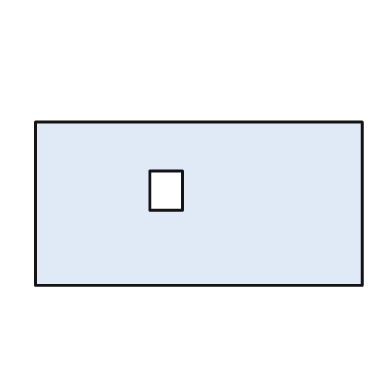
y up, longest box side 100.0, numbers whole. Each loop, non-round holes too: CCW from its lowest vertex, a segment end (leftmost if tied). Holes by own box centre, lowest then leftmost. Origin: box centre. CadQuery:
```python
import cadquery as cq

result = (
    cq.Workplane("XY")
    .moveTo(-50.0, -25.0)
    .lineTo(50.0, -25.0)
    .lineTo(50.0, 25.0)
    .lineTo(-50.0, 25.0)
    .close()
    .moveTo(-15.0, -2.0)
    .lineTo(-5.0, -2.0)
    .lineTo(-5.0, 10.0)
    .lineTo(-15.0, 10.0)
    .close()
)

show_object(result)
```